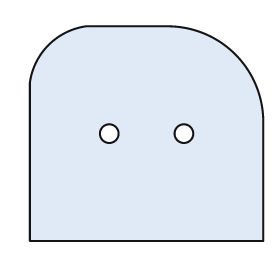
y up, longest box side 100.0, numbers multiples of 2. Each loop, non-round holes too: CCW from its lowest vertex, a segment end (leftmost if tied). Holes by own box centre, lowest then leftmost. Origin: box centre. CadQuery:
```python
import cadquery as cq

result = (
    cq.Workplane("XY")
    .moveTo(-50.0, -46.0)
    .lineTo(50.0, -46.0)
    .lineTo(50.0, 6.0)
    .threePointArc((38.0, 34.0), (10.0, 46.0))
    .lineTo(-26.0, 46.0)
    .threePointArc((-42.0, 38.0), (-50.0, 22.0))
    .close()
    .moveTo(-16.0, 0.0)
    .circle(4.0)
    .moveTo(16.0, 0.0)
    .circle(4.0)
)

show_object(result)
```